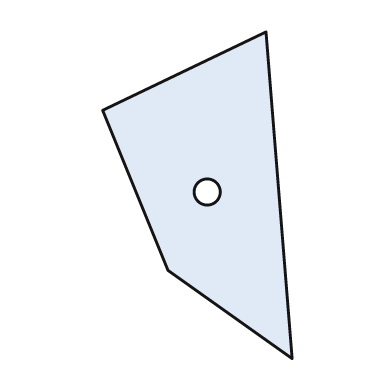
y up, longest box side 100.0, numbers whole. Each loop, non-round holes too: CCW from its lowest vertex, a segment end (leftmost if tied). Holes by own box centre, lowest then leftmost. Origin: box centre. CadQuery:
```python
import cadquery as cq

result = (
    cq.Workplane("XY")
    .moveTo(29.0, -50.0)
    .lineTo(21.0, 50.0)
    .lineTo(-29.0, 26.0)
    .lineTo(-9.0, -23.0)
    .close()
    .moveTo(3.0, 1.0)
    .circle(4.0)
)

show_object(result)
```